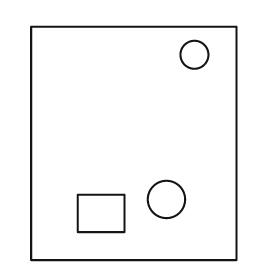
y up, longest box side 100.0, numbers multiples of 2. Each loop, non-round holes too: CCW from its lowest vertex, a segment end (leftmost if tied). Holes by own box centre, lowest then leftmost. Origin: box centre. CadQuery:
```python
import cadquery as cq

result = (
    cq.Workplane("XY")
    .moveTo(-44.0, -50.0)
    .lineTo(44.0, -50.0)
    .lineTo(44.0, 50.0)
    .lineTo(-44.0, 50.0)
    .close()
    .moveTo(-24.0, -38.0)
    .lineTo(-4.0, -38.0)
    .lineTo(-4.0, -22.0)
    .lineTo(-24.0, -22.0)
    .close()
    .moveTo(14.0, -24.0)
    .circle(8.0)
    .moveTo(26.0, 38.0)
    .circle(6.0)
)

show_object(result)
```